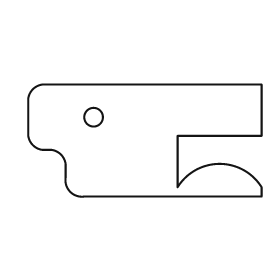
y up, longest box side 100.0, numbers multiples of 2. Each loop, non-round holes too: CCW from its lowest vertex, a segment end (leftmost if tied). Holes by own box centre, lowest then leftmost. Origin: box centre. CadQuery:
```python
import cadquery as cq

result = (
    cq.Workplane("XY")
    .moveTo(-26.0, -24.0)
    .lineTo(50.0, -24.0)
    .lineTo(50.0, -20.0)
    .threePointArc((32.0, -10.0), (14.0, -20.0))
    .lineTo(14.0, 2.0)
    .lineTo(50.0, 2.0)
    .lineTo(50.0, 24.0)
    .lineTo(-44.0, 24.0)
    .threePointArc((-48.0, 22.0), (-50.0, 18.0))
    .lineTo(-50.0, 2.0)
    .threePointArc((-48.0, -2.0), (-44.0, -4.0))
    .lineTo(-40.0, -4.0)
    .threePointArc((-36.0, -6.0), (-34.0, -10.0))
    .lineTo(-34.0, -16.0)
    .threePointArc((-32.0, -22.0), (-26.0, -24.0))
    .close()
    .moveTo(-22.0, 10.0)
    .circle(4.0)
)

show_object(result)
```